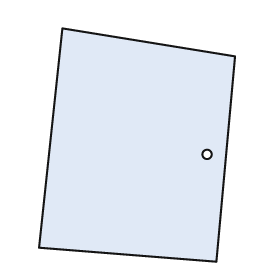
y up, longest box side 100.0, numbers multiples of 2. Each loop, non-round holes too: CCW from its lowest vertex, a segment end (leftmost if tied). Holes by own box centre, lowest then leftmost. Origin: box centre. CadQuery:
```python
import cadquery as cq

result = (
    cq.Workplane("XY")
    .moveTo(34.0, -50.0)
    .lineTo(42.0, 38.0)
    .lineTo(-32.0, 50.0)
    .lineTo(-42.0, -44.0)
    .close()
    .moveTo(30.0, -4.0)
    .circle(2.0)
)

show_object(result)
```